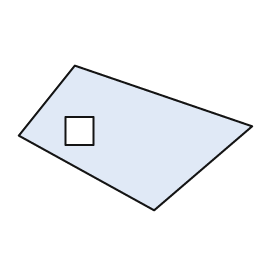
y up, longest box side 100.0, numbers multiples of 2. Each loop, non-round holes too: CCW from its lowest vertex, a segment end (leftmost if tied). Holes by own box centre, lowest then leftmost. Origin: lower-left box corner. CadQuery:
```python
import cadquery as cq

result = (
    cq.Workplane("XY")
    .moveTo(58.0, 0.0)
    .lineTo(100.0, 36.0)
    .lineTo(24.0, 62.0)
    .lineTo(0.0, 32.0)
    .close()
    .moveTo(20.0, 28.0)
    .lineTo(32.0, 28.0)
    .lineTo(32.0, 40.0)
    .lineTo(20.0, 40.0)
    .close()
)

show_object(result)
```